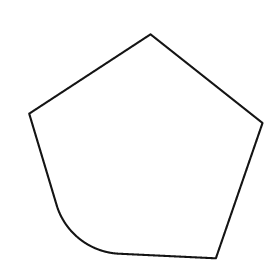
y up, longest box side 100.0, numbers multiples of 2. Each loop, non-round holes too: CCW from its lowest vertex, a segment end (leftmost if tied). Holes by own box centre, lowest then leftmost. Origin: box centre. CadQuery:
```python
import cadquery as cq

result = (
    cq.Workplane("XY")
    .moveTo(30.0, -48.0)
    .lineTo(50.0, 10.0)
    .lineTo(2.0, 48.0)
    .lineTo(-50.0, 14.0)
    .lineTo(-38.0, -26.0)
    .threePointArc((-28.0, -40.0), (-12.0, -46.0))
    .close()
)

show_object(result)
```